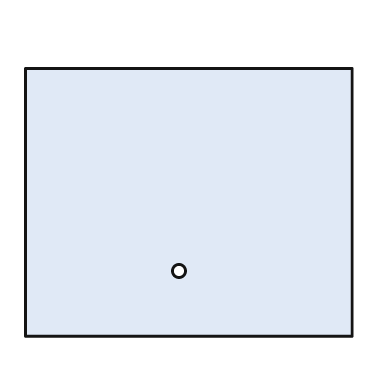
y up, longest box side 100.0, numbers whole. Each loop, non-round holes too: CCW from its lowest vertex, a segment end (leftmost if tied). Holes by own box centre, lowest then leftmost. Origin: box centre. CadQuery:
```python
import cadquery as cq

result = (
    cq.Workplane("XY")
    .moveTo(-50.0, -41.0)
    .lineTo(50.0, -41.0)
    .lineTo(50.0, 41.0)
    .lineTo(-50.0, 41.0)
    .close()
    .moveTo(-3.0, -21.0)
    .circle(2.0)
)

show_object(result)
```